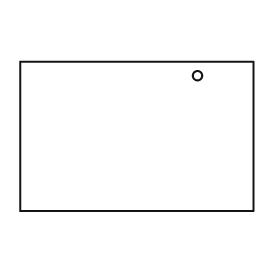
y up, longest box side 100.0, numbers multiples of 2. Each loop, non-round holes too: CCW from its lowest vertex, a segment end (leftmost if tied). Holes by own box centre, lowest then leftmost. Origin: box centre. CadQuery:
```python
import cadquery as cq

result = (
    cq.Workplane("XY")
    .moveTo(-50.0, -32.0)
    .lineTo(50.0, -32.0)
    .lineTo(50.0, 32.0)
    .lineTo(-50.0, 32.0)
    .close()
    .moveTo(26.0, 26.0)
    .circle(2.0)
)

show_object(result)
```